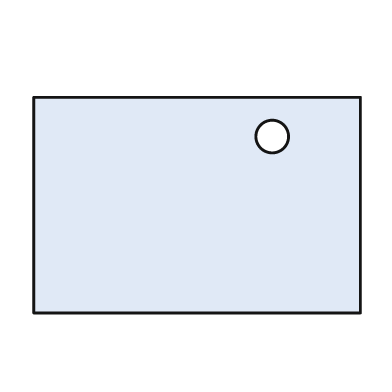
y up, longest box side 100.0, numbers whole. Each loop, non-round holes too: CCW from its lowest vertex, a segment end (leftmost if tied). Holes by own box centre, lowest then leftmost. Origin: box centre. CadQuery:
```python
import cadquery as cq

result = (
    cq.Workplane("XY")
    .moveTo(-50.0, -33.0)
    .lineTo(50.0, -33.0)
    .lineTo(50.0, 33.0)
    .lineTo(-50.0, 33.0)
    .close()
    .moveTo(23.0, 21.0)
    .circle(5.0)
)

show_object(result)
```